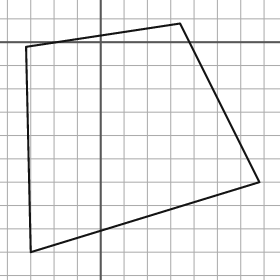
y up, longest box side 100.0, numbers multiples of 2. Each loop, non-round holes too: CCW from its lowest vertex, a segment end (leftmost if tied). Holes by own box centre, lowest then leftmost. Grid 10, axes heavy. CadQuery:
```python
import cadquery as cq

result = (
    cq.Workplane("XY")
    .moveTo(-30.0, -90.0)
    .lineTo(68.0, -60.0)
    .lineTo(34.0, 8.0)
    .lineTo(-32.0, -2.0)
    .close()
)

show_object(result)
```